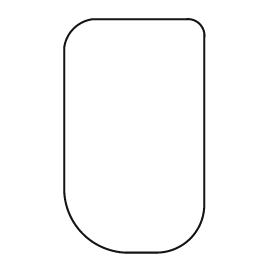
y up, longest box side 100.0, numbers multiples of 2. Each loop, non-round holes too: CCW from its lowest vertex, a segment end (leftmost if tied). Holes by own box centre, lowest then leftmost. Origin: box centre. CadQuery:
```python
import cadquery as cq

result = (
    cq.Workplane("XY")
    .moveTo(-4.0, -50.0)
    .lineTo(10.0, -50.0)
    .threePointArc((24.0, -44.0), (30.0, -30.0))
    .lineTo(30.0, 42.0)
    .threePointArc((28.0, 48.0), (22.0, 50.0))
    .lineTo(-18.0, 50.0)
    .threePointArc((-26.0, 46.0), (-30.0, 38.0))
    .lineTo(-30.0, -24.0)
    .threePointArc((-22.0, -42.0), (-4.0, -50.0))
    .close()
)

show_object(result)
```